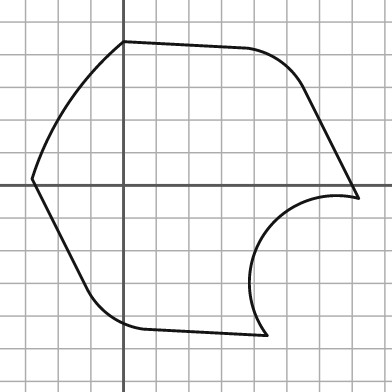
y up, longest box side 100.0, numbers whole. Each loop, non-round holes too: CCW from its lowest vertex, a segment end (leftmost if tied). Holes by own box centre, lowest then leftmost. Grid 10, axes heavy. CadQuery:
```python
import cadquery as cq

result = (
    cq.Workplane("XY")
    .moveTo(44.0, -46.0)
    .threePointArc((43.0, -15.0), (72.0, -4.0))
    .lineTo(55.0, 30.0)
    .threePointArc((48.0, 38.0), (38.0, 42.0))
    .lineTo(0.0, 44.0)
    .threePointArc((-17.0, 25.0), (-28.0, 2.0))
    .lineTo(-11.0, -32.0)
    .threePointArc((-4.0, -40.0), (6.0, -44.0))
    .close()
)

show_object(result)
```